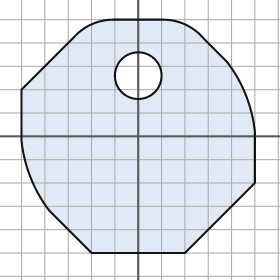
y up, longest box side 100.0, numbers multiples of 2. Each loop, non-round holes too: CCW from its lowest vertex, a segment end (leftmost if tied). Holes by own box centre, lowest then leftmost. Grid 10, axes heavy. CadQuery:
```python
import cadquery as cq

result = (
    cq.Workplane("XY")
    .moveTo(-20.0, -50.0)
    .lineTo(20.0, -50.0)
    .lineTo(50.0, -20.0)
    .lineTo(50.0, 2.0)
    .threePointArc((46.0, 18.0), (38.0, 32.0))
    .lineTo(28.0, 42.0)
    .threePointArc((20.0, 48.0), (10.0, 50.0))
    .lineTo(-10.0, 50.0)
    .threePointArc((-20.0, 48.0), (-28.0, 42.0))
    .lineTo(-50.0, 20.0)
    .lineTo(-50.0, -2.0)
    .threePointArc((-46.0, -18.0), (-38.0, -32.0))
    .close()
    .moveTo(0.0, 26.0)
    .circle(10.0)
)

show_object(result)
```